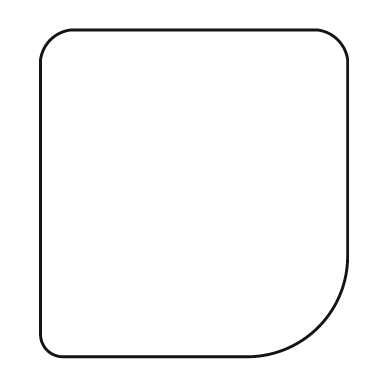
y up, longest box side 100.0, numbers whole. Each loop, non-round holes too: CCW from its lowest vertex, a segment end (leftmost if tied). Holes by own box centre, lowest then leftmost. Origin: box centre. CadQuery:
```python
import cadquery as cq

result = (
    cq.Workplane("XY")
    .moveTo(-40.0, -50.0)
    .lineTo(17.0, -50.0)
    .threePointArc((38.0, -41.0), (47.0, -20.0))
    .lineTo(47.0, 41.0)
    .threePointArc((44.0, 47.0), (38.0, 50.0))
    .lineTo(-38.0, 50.0)
    .threePointArc((-44.0, 47.0), (-47.0, 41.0))
    .lineTo(-47.0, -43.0)
    .threePointArc((-45.0, -48.0), (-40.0, -50.0))
    .close()
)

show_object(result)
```